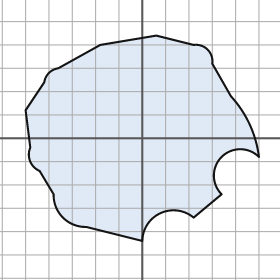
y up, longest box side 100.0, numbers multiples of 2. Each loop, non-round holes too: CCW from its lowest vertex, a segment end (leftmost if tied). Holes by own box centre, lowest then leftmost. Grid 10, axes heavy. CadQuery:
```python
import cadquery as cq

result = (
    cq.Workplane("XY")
    .moveTo(0.0, -44.0)
    .threePointArc((8.0, -32.0), (22.0, -34.0))
    .lineTo(34.0, -24.0)
    .threePointArc((34.0, -8.0), (50.0, -8.0))
    .threePointArc((46.0, 6.0), (38.0, 18.0))
    .lineTo(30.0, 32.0)
    .threePointArc((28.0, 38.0), (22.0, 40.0))
    .lineTo(6.0, 44.0)
    .lineTo(-18.0, 40.0)
    .lineTo(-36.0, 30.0)
    .threePointArc((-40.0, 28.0), (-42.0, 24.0))
    .lineTo(-50.0, 12.0)
    .lineTo(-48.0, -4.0)
    .threePointArc((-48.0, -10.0), (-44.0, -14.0))
    .lineTo(-38.0, -24.0)
    .threePointArc((-34.0, -34.0), (-24.0, -38.0))
    .close()
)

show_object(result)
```